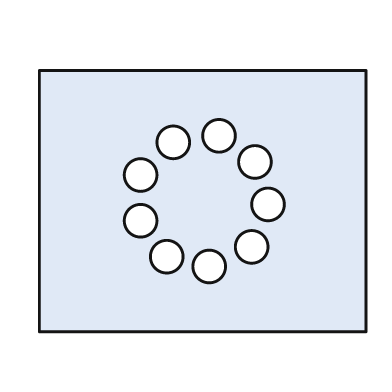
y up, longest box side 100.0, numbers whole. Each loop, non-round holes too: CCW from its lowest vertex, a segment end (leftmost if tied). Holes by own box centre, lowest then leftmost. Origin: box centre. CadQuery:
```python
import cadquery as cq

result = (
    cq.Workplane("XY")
    .moveTo(-50.0, -40.0)
    .lineTo(50.0, -40.0)
    .lineTo(50.0, 40.0)
    .lineTo(-50.0, 40.0)
    .close()
    .moveTo(2.0, -20.0)
    .circle(5.0)
    .moveTo(-11.0, -17.0)
    .circle(5.0)
    .moveTo(15.0, -14.0)
    .circle(5.0)
    .moveTo(-19.0, -6.0)
    .circle(5.0)
    .moveTo(20.0, -1.0)
    .circle(5.0)
    .moveTo(-19.0, 8.0)
    .circle(5.0)
    .moveTo(16.0, 12.0)
    .circle(5.0)
    .moveTo(-9.0, 18.0)
    .circle(5.0)
    .moveTo(5.0, 20.0)
    .circle(5.0)
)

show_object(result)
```